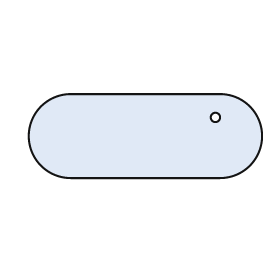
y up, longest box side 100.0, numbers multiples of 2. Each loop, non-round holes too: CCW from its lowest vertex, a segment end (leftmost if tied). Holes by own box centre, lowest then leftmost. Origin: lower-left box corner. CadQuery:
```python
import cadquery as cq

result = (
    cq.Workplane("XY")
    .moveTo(18.0, 0.0)
    .lineTo(82.0, 0.0)
    .threePointArc((100.0, 18.0), (82.0, 36.0))
    .lineTo(18.0, 36.0)
    .threePointArc((0.0, 18.0), (18.0, 0.0))
    .close()
    .moveTo(80.0, 26.0)
    .circle(2.0)
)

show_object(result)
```